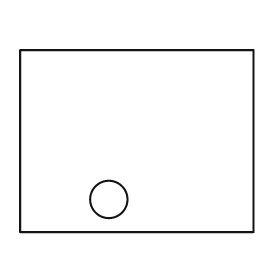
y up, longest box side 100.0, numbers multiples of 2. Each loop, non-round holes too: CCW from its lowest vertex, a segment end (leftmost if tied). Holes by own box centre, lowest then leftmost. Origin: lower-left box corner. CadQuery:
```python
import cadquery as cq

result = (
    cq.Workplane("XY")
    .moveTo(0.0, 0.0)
    .lineTo(100.0, 0.0)
    .lineTo(100.0, 78.0)
    .lineTo(0.0, 78.0)
    .close()
    .moveTo(38.0, 14.0)
    .circle(8.0)
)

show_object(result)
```